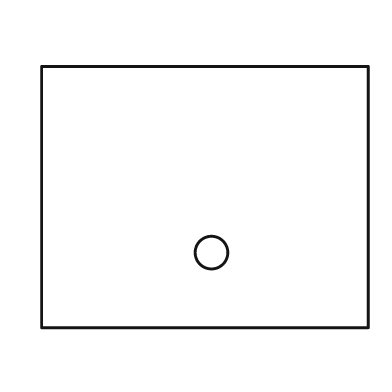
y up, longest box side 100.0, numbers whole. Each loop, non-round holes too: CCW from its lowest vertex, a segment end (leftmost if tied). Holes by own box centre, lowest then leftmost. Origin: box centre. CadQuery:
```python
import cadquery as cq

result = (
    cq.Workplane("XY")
    .moveTo(-50.0, -40.0)
    .lineTo(50.0, -40.0)
    .lineTo(50.0, 40.0)
    .lineTo(-50.0, 40.0)
    .close()
    .moveTo(2.0, -17.0)
    .circle(5.0)
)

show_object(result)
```